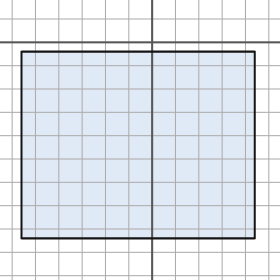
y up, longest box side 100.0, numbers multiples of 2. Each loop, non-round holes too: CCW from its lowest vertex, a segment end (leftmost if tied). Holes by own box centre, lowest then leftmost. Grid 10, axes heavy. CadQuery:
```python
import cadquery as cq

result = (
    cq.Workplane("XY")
    .moveTo(-56.0, -84.0)
    .lineTo(44.0, -84.0)
    .lineTo(44.0, -4.0)
    .lineTo(-56.0, -4.0)
    .close()
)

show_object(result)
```